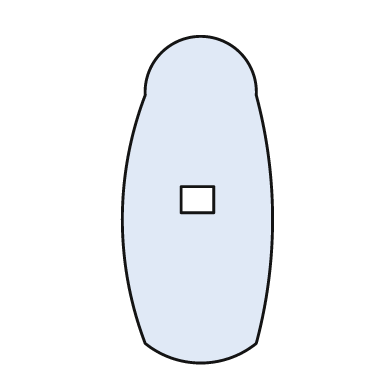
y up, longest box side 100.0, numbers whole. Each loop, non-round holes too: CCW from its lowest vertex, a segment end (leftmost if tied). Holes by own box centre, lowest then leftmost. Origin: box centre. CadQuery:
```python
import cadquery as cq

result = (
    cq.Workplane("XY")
    .moveTo(-16.0, -44.0)
    .threePointArc((1.0, -50.0), (18.0, -44.0))
    .threePointArc((23.0, -6.0), (18.0, 32.0))
    .threePointArc((1.0, 50.0), (-16.0, 32.0))
    .threePointArc((-23.0, -6.0), (-16.0, -44.0))
    .close()
    .moveTo(-5.0, -4.0)
    .lineTo(5.0, -4.0)
    .lineTo(5.0, 4.0)
    .lineTo(-5.0, 4.0)
    .close()
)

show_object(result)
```